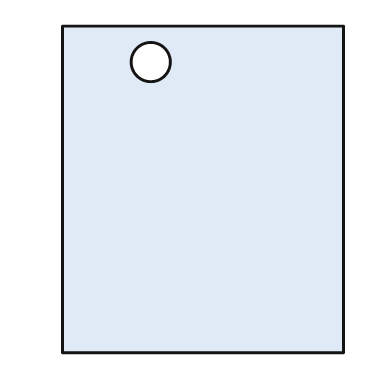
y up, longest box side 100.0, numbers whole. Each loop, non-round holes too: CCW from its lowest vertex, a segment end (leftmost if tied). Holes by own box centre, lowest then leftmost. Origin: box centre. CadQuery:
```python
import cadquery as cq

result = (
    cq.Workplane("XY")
    .moveTo(-43.0, -50.0)
    .lineTo(43.0, -50.0)
    .lineTo(43.0, 50.0)
    .lineTo(-43.0, 50.0)
    .close()
    .moveTo(-16.0, 39.0)
    .circle(6.0)
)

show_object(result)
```